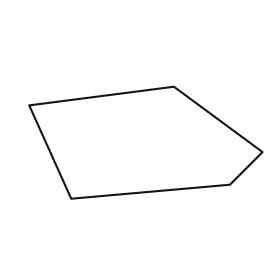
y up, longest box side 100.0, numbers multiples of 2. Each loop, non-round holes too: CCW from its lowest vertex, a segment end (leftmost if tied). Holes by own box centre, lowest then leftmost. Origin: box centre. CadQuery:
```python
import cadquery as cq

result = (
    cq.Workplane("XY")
    .moveTo(-32.0, -24.0)
    .lineTo(36.0, -18.0)
    .lineTo(50.0, -4.0)
    .lineTo(12.0, 24.0)
    .lineTo(-50.0, 16.0)
    .close()
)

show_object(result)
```